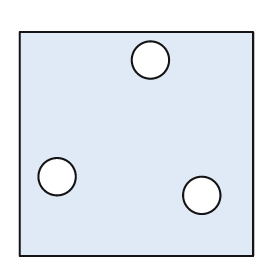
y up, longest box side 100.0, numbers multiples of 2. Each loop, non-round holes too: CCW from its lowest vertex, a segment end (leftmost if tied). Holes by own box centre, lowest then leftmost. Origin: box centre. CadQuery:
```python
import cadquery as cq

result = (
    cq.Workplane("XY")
    .moveTo(-50.0, -48.0)
    .lineTo(50.0, -48.0)
    .lineTo(50.0, 48.0)
    .lineTo(-50.0, 48.0)
    .close()
    .moveTo(28.0, -22.0)
    .circle(8.0)
    .moveTo(-34.0, -14.0)
    .circle(8.0)
    .moveTo(6.0, 36.0)
    .circle(8.0)
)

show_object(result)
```